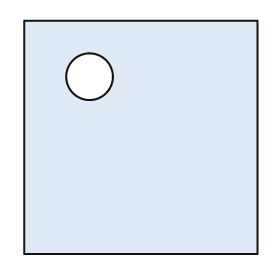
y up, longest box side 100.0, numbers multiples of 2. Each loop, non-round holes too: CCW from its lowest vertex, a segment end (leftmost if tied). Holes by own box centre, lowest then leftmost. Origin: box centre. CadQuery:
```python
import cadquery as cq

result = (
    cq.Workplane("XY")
    .moveTo(-50.0, -50.0)
    .lineTo(50.0, -50.0)
    .lineTo(50.0, 50.0)
    .lineTo(-50.0, 50.0)
    .close()
    .moveTo(-22.0, 26.0)
    .circle(10.0)
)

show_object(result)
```